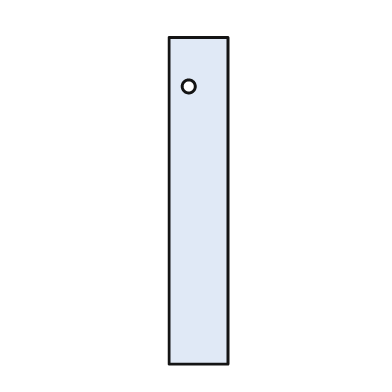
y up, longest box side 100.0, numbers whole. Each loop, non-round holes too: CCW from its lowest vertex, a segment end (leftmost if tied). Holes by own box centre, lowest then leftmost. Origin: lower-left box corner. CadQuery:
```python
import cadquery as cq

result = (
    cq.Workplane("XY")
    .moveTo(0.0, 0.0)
    .lineTo(18.0, 0.0)
    .lineTo(18.0, 100.0)
    .lineTo(0.0, 100.0)
    .close()
    .moveTo(6.0, 85.0)
    .circle(2.0)
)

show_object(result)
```